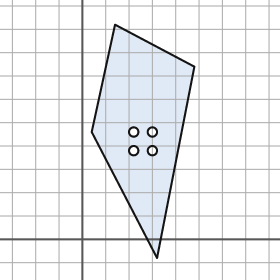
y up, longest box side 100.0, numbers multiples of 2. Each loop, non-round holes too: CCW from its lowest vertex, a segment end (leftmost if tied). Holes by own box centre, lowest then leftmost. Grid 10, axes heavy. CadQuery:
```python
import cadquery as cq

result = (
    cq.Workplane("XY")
    .moveTo(32.0, -8.0)
    .lineTo(48.0, 74.0)
    .lineTo(14.0, 92.0)
    .lineTo(4.0, 46.0)
    .close()
    .moveTo(22.0, 38.0)
    .circle(2.0)
    .moveTo(30.0, 38.0)
    .circle(2.0)
    .moveTo(22.0, 46.0)
    .circle(2.0)
    .moveTo(30.0, 46.0)
    .circle(2.0)
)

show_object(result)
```